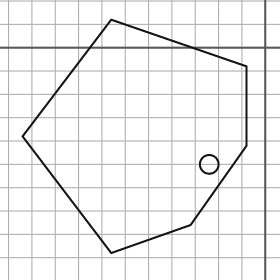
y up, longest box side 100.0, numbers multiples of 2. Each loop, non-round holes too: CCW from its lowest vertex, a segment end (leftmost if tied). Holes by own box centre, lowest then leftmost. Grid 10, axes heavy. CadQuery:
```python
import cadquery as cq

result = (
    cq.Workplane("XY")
    .moveTo(-66.0, -88.0)
    .lineTo(-32.0, -76.0)
    .lineTo(-8.0, -42.0)
    .lineTo(-8.0, -8.0)
    .lineTo(-66.0, 12.0)
    .lineTo(-104.0, -38.0)
    .close()
    .moveTo(-24.0, -50.0)
    .circle(4.0)
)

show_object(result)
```